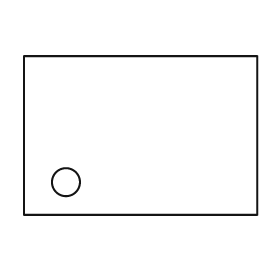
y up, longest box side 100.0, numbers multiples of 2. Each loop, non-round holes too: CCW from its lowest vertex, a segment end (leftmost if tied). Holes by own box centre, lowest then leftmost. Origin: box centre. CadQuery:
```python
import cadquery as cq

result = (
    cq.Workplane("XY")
    .moveTo(-50.0, -34.0)
    .lineTo(50.0, -34.0)
    .lineTo(50.0, 34.0)
    .lineTo(-50.0, 34.0)
    .close()
    .moveTo(-32.0, -20.0)
    .circle(6.0)
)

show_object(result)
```